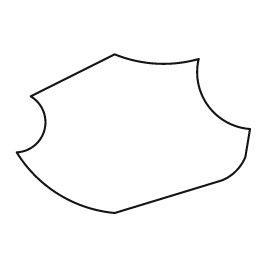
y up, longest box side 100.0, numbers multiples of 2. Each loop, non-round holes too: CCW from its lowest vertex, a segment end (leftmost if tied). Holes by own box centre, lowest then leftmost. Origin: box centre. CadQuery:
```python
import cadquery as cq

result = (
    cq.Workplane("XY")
    .moveTo(-8.0, -34.0)
    .lineTo(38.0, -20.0)
    .threePointArc((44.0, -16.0), (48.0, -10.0))
    .lineTo(50.0, 2.0)
    .threePointArc((32.0, 12.0), (28.0, 32.0))
    .threePointArc((10.0, 30.0), (-8.0, 34.0))
    .lineTo(-44.0, 16.0)
    .threePointArc((-38.0, 2.0), (-50.0, -8.0))
    .threePointArc((-32.0, -26.0), (-8.0, -34.0))
    .close()
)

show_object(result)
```